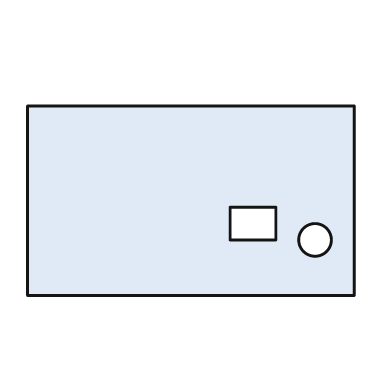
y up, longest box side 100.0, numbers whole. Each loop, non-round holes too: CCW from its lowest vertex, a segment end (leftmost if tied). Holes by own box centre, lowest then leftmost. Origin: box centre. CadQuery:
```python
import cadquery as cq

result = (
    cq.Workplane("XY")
    .moveTo(-50.0, -29.0)
    .lineTo(50.0, -29.0)
    .lineTo(50.0, 29.0)
    .lineTo(-50.0, 29.0)
    .close()
    .moveTo(38.0, -12.0)
    .circle(5.0)
    .moveTo(12.0, -12.0)
    .lineTo(26.0, -12.0)
    .lineTo(26.0, -2.0)
    .lineTo(12.0, -2.0)
    .close()
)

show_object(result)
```